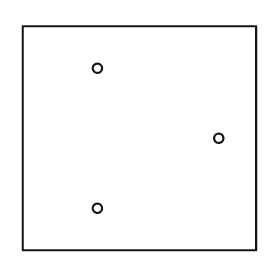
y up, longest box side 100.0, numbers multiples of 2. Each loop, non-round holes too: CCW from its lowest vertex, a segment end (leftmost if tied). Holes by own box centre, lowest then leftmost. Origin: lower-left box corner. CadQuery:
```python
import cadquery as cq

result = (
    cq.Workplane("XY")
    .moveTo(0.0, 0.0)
    .lineTo(100.0, 0.0)
    .lineTo(100.0, 96.0)
    .lineTo(0.0, 96.0)
    .close()
    .moveTo(32.0, 18.0)
    .circle(2.0)
    .moveTo(84.0, 48.0)
    .circle(2.0)
    .moveTo(32.0, 78.0)
    .circle(2.0)
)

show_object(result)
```